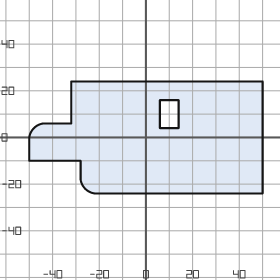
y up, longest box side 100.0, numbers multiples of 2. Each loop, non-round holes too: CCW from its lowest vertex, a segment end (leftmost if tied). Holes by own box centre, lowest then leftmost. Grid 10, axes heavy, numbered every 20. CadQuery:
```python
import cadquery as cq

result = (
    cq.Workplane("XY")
    .moveTo(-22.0, -24.0)
    .lineTo(50.0, -24.0)
    .lineTo(50.0, 24.0)
    .lineTo(-32.0, 24.0)
    .lineTo(-32.0, 6.0)
    .lineTo(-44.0, 6.0)
    .threePointArc((-48.0, 4.0), (-50.0, 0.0))
    .lineTo(-50.0, -10.0)
    .lineTo(-28.0, -10.0)
    .lineTo(-28.0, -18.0)
    .threePointArc((-26.0, -22.0), (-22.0, -24.0))
    .close()
    .moveTo(6.0, 4.0)
    .lineTo(14.0, 4.0)
    .lineTo(14.0, 16.0)
    .lineTo(6.0, 16.0)
    .close()
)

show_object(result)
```